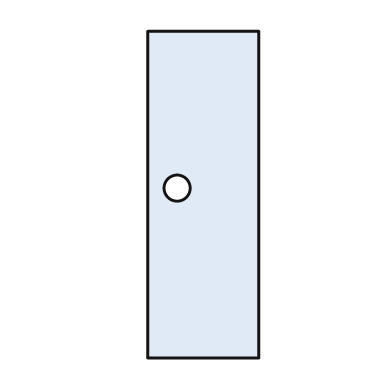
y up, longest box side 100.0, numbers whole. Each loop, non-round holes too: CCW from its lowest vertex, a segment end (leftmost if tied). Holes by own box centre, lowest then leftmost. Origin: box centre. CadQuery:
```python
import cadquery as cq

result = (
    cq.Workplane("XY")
    .moveTo(-17.0, -50.0)
    .lineTo(17.0, -50.0)
    .lineTo(17.0, 50.0)
    .lineTo(-17.0, 50.0)
    .close()
    .moveTo(-8.0, 2.0)
    .circle(4.0)
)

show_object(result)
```